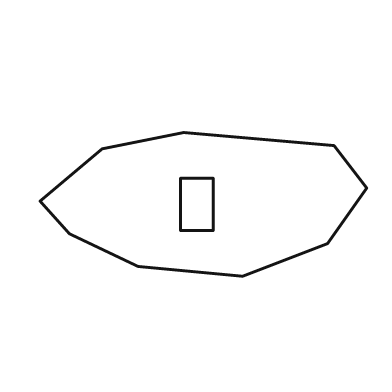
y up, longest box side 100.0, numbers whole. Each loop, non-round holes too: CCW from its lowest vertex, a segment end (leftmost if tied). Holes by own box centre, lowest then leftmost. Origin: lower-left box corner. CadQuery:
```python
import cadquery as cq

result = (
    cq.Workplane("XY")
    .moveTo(62.0, 0.0)
    .lineTo(88.0, 10.0)
    .lineTo(100.0, 27.0)
    .lineTo(90.0, 40.0)
    .lineTo(44.0, 44.0)
    .lineTo(19.0, 39.0)
    .lineTo(0.0, 23.0)
    .lineTo(9.0, 13.0)
    .lineTo(30.0, 3.0)
    .close()
    .moveTo(43.0, 14.0)
    .lineTo(53.0, 14.0)
    .lineTo(53.0, 30.0)
    .lineTo(43.0, 30.0)
    .close()
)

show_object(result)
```